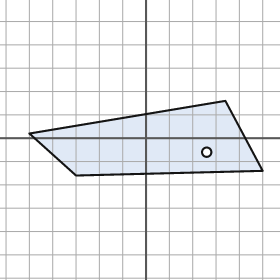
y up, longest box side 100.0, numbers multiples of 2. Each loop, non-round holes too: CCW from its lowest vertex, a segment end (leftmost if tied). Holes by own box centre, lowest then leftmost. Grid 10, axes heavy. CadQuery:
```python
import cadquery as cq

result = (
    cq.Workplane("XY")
    .moveTo(-30.0, -16.0)
    .lineTo(50.0, -14.0)
    .lineTo(34.0, 16.0)
    .lineTo(-50.0, 2.0)
    .close()
    .moveTo(26.0, -6.0)
    .circle(2.0)
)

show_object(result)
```